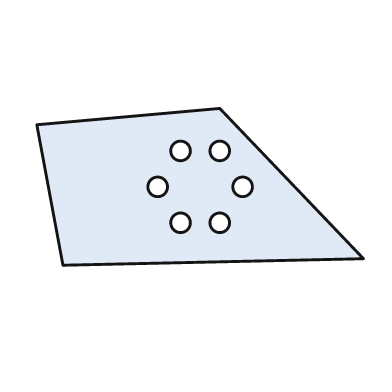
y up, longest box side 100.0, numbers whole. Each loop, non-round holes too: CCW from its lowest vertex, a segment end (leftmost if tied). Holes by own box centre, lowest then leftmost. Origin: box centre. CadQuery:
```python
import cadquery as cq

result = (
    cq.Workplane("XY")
    .moveTo(-42.0, -24.0)
    .lineTo(50.0, -22.0)
    .lineTo(6.0, 24.0)
    .lineTo(-50.0, 19.0)
    .close()
    .moveTo(-6.0, -11.0)
    .circle(3.0)
    .moveTo(6.0, -11.0)
    .circle(3.0)
    .moveTo(-13.0, 0.0)
    .circle(3.0)
    .moveTo(13.0, 0.0)
    .circle(3.0)
    .moveTo(-6.0, 11.0)
    .circle(3.0)
    .moveTo(6.0, 11.0)
    .circle(3.0)
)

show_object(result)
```